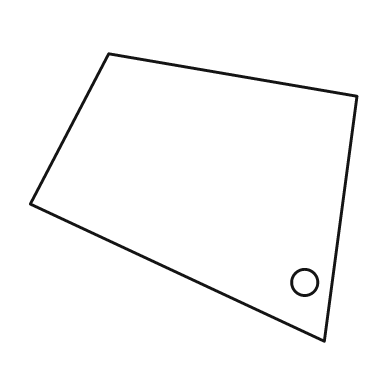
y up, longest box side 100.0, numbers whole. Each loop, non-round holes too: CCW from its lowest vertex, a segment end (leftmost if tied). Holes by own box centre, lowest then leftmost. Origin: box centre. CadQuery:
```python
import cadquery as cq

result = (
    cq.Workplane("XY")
    .moveTo(40.0, -44.0)
    .lineTo(50.0, 31.0)
    .lineTo(-26.0, 44.0)
    .lineTo(-50.0, -2.0)
    .close()
    .moveTo(34.0, -26.0)
    .circle(4.0)
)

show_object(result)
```